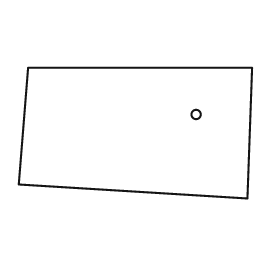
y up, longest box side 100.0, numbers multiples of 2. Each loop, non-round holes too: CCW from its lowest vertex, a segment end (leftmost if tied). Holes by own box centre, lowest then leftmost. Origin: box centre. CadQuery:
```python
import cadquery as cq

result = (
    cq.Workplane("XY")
    .moveTo(48.0, -28.0)
    .lineTo(50.0, 28.0)
    .lineTo(-46.0, 28.0)
    .lineTo(-50.0, -22.0)
    .close()
    .moveTo(26.0, 8.0)
    .circle(2.0)
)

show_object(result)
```